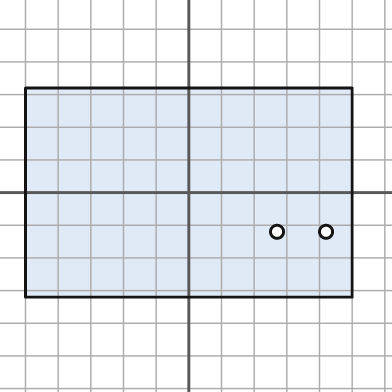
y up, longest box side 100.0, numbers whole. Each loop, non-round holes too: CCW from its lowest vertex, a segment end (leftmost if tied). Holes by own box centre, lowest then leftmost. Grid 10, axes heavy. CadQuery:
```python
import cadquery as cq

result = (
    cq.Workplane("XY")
    .moveTo(-50.0, -32.0)
    .lineTo(50.0, -32.0)
    .lineTo(50.0, 32.0)
    .lineTo(-50.0, 32.0)
    .close()
    .moveTo(27.0, -12.0)
    .circle(2.0)
    .moveTo(42.0, -12.0)
    .circle(2.0)
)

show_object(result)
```